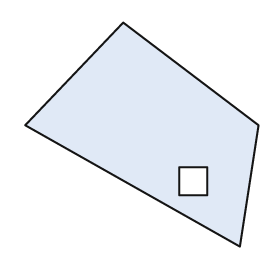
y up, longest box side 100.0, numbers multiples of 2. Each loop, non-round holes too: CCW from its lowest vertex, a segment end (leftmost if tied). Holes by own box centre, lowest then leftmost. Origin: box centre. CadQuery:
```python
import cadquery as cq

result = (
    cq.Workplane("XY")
    .moveTo(42.0, -48.0)
    .lineTo(50.0, 4.0)
    .lineTo(-8.0, 48.0)
    .lineTo(-50.0, 4.0)
    .close()
    .moveTo(16.0, -26.0)
    .lineTo(28.0, -26.0)
    .lineTo(28.0, -14.0)
    .lineTo(16.0, -14.0)
    .close()
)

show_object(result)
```